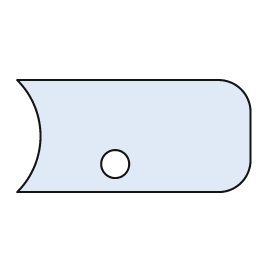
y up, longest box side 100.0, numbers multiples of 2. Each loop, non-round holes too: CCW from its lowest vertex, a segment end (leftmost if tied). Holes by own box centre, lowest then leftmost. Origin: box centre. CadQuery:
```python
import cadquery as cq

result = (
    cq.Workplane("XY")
    .moveTo(-50.0, -24.0)
    .lineTo(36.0, -24.0)
    .threePointArc((46.0, -20.0), (50.0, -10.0))
    .lineTo(50.0, 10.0)
    .threePointArc((46.0, 20.0), (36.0, 24.0))
    .lineTo(-50.0, 24.0)
    .threePointArc((-40.0, 0.0), (-50.0, -24.0))
    .close()
    .moveTo(-8.0, -12.0)
    .circle(6.0)
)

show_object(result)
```